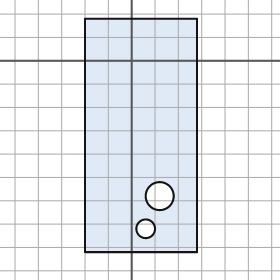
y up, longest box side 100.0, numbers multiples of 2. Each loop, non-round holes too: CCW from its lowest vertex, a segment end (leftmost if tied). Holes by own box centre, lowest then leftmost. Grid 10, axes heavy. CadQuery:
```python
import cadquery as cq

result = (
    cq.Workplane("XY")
    .moveTo(-20.0, -82.0)
    .lineTo(28.0, -82.0)
    .lineTo(28.0, 18.0)
    .lineTo(-20.0, 18.0)
    .close()
    .moveTo(6.0, -72.0)
    .circle(4.0)
    .moveTo(12.0, -58.0)
    .circle(6.0)
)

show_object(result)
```